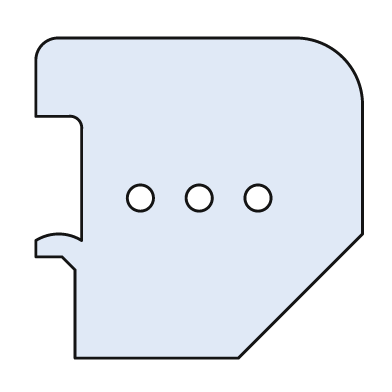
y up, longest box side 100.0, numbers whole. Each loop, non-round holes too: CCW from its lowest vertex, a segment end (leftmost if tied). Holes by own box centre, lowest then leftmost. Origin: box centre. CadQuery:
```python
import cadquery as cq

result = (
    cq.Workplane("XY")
    .moveTo(-38.0, -49.0)
    .lineTo(12.0, -49.0)
    .lineTo(50.0, -11.0)
    .lineTo(50.0, 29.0)
    .threePointArc((44.0, 43.0), (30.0, 49.0))
    .lineTo(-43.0, 49.0)
    .threePointArc((-48.0, 47.0), (-50.0, 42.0))
    .lineTo(-50.0, 25.0)
    .lineTo(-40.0, 25.0)
    .threePointArc((-37.0, 24.0), (-36.0, 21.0))
    .lineTo(-36.0, -13.0)
    .threePointArc((-43.0, -11.0), (-50.0, -13.0))
    .lineTo(-50.0, -18.0)
    .lineTo(-42.0, -18.0)
    .lineTo(-38.0, -22.0)
    .close()
    .moveTo(-18.0, 0.0)
    .circle(4.0)
    .moveTo(0.0, 0.0)
    .circle(4.0)
    .moveTo(18.0, 0.0)
    .circle(4.0)
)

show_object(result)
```